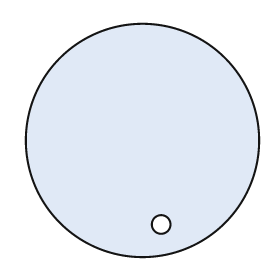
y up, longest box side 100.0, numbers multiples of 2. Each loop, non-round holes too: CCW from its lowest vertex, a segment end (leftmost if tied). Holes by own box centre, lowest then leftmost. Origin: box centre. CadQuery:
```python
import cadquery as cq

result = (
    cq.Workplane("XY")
    .moveTo(0.0, 0.0)
    .circle(50.0)
    .moveTo(8.0, -36.0)
    .circle(4.0)
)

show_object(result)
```